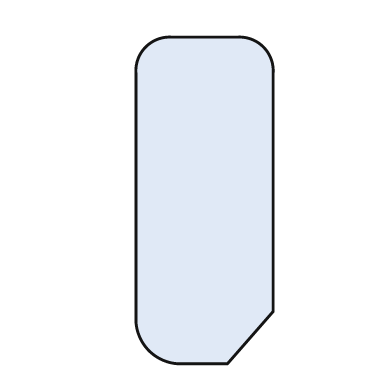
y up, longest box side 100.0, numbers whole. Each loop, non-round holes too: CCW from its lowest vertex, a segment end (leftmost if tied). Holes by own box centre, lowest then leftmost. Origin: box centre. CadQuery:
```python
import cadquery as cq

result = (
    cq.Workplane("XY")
    .moveTo(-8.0, -50.0)
    .lineTo(7.0, -50.0)
    .lineTo(21.0, -34.0)
    .lineTo(21.0, 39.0)
    .threePointArc((18.0, 47.0), (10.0, 50.0))
    .lineTo(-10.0, 50.0)
    .threePointArc((-18.0, 47.0), (-21.0, 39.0))
    .lineTo(-21.0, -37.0)
    .threePointArc((-17.0, -46.0), (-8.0, -50.0))
    .close()
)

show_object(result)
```